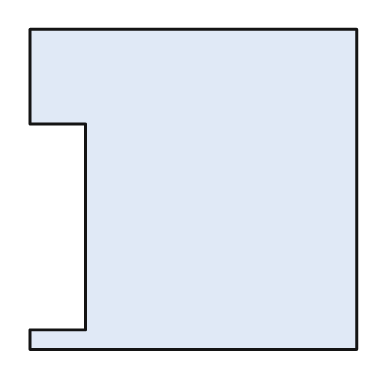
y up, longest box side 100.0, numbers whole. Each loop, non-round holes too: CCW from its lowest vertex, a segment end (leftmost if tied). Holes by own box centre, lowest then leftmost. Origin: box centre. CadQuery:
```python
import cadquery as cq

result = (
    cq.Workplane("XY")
    .moveTo(-50.0, -49.0)
    .lineTo(50.0, -49.0)
    .lineTo(50.0, 49.0)
    .lineTo(-50.0, 49.0)
    .lineTo(-50.0, 20.0)
    .lineTo(-33.0, 20.0)
    .lineTo(-33.0, -43.0)
    .lineTo(-50.0, -43.0)
    .close()
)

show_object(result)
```